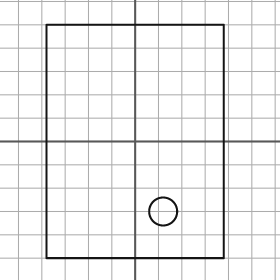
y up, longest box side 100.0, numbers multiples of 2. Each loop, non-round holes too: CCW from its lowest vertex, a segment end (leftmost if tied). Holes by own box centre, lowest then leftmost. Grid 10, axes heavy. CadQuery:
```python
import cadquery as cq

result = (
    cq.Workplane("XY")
    .moveTo(-38.0, -50.0)
    .lineTo(38.0, -50.0)
    .lineTo(38.0, 50.0)
    .lineTo(-38.0, 50.0)
    .close()
    .moveTo(12.0, -30.0)
    .circle(6.0)
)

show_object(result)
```